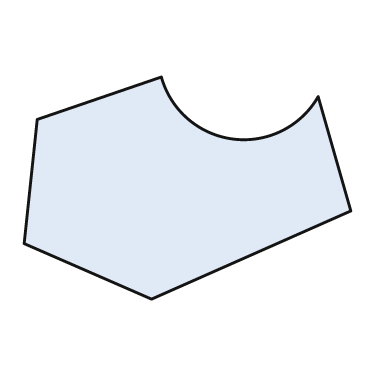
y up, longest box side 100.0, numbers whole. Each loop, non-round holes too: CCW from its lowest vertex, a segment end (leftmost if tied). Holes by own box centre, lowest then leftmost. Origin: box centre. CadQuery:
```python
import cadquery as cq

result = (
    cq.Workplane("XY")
    .moveTo(-11.0, -34.0)
    .lineTo(50.0, -7.0)
    .lineTo(40.0, 28.0)
    .threePointArc((14.0, 15.0), (-8.0, 34.0))
    .lineTo(-46.0, 21.0)
    .lineTo(-50.0, -17.0)
    .close()
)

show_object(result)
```